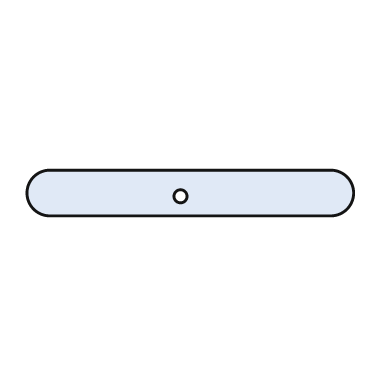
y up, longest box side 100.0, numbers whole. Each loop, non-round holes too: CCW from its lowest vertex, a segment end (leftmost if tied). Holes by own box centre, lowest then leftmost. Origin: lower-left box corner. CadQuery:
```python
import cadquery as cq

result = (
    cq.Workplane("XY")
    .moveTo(7.0, 0.0)
    .lineTo(93.0, 0.0)
    .threePointArc((100.0, 7.0), (93.0, 14.0))
    .lineTo(7.0, 14.0)
    .threePointArc((0.0, 7.0), (7.0, 0.0))
    .close()
    .moveTo(47.0, 6.0)
    .circle(2.0)
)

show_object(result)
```